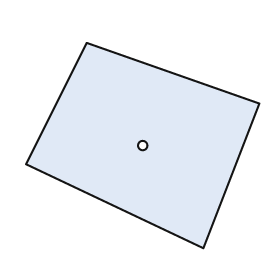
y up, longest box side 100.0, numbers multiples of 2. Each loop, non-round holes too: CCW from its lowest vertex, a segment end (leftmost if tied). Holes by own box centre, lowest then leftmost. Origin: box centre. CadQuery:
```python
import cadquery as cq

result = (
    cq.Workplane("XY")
    .moveTo(26.0, -44.0)
    .lineTo(50.0, 18.0)
    .lineTo(-24.0, 44.0)
    .lineTo(-50.0, -8.0)
    .close()
    .moveTo(0.0, 0.0)
    .circle(2.0)
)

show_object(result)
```